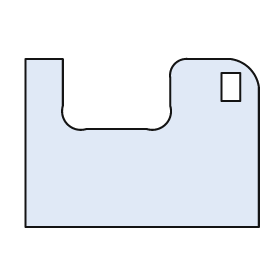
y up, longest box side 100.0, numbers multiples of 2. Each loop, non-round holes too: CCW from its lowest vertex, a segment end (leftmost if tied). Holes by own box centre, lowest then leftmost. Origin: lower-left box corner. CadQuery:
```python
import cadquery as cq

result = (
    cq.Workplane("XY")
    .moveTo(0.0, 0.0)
    .lineTo(100.0, 0.0)
    .lineTo(100.0, 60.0)
    .threePointArc((96.0, 68.0), (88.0, 72.0))
    .lineTo(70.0, 72.0)
    .threePointArc((64.0, 70.0), (62.0, 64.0))
    .lineTo(62.0, 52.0)
    .threePointArc((60.0, 44.0), (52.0, 42.0))
    .lineTo(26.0, 42.0)
    .threePointArc((18.0, 44.0), (16.0, 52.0))
    .lineTo(16.0, 72.0)
    .lineTo(0.0, 72.0)
    .close()
    .moveTo(84.0, 54.0)
    .lineTo(92.0, 54.0)
    .lineTo(92.0, 66.0)
    .lineTo(84.0, 66.0)
    .close()
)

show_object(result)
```